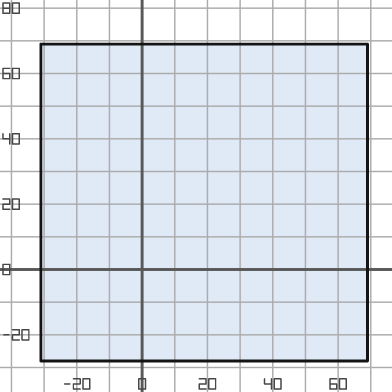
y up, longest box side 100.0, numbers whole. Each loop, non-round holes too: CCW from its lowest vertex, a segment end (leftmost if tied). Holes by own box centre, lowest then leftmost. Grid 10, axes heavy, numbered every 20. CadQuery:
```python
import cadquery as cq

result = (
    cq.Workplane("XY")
    .moveTo(-31.0, -28.0)
    .lineTo(69.0, -28.0)
    .lineTo(69.0, 69.0)
    .lineTo(-31.0, 69.0)
    .close()
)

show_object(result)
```